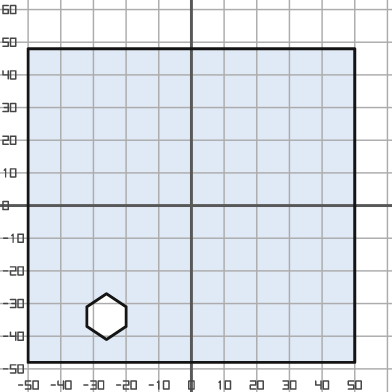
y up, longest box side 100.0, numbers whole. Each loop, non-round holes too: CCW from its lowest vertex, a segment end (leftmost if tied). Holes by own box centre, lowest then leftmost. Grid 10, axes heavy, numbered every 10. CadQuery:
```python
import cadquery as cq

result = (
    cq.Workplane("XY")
    .moveTo(-50.0, -48.0)
    .lineTo(50.0, -48.0)
    .lineTo(50.0, 48.0)
    .lineTo(-50.0, 48.0)
    .close()
    .moveTo(-26.0, -41.0)
    .lineTo(-20.0, -37.0)
    .lineTo(-20.0, -31.0)
    .lineTo(-26.0, -27.0)
    .lineTo(-32.0, -31.0)
    .lineTo(-32.0, -37.0)
    .close()
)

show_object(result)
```